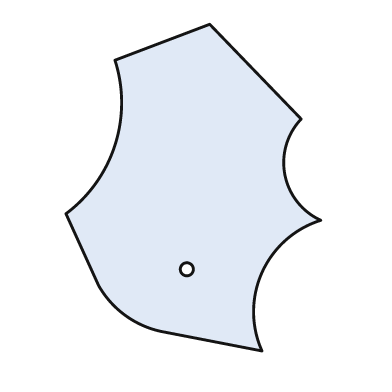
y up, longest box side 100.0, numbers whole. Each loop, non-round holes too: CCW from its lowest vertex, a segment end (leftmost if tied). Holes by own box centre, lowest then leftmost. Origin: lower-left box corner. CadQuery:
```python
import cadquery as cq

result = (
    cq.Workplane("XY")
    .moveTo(60.0, 0.0)
    .threePointArc((60.0, 24.0), (78.0, 40.0))
    .threePointArc((67.0, 54.0), (72.0, 71.0))
    .lineTo(44.0, 100.0)
    .lineTo(15.0, 89.0)
    .threePointArc((15.0, 63.0), (0.0, 42.0))
    .lineTo(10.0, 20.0)
    .threePointArc((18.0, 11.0), (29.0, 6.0))
    .close()
    .moveTo(37.0, 25.0)
    .circle(2.0)
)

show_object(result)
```